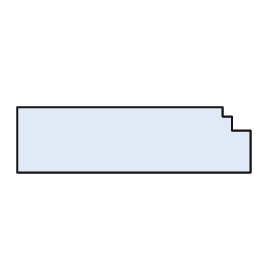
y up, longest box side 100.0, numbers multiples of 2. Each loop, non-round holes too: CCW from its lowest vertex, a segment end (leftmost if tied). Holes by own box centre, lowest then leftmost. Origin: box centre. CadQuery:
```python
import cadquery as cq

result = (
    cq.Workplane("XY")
    .moveTo(-50.0, -14.0)
    .lineTo(50.0, -14.0)
    .lineTo(50.0, 4.0)
    .lineTo(42.0, 4.0)
    .lineTo(42.0, 10.0)
    .lineTo(38.0, 10.0)
    .lineTo(38.0, 14.0)
    .lineTo(-50.0, 14.0)
    .close()
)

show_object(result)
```